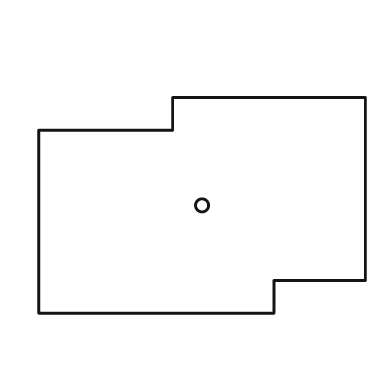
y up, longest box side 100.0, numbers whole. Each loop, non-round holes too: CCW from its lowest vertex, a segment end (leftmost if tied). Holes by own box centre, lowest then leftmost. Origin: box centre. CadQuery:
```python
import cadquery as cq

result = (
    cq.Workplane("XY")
    .moveTo(-50.0, -33.0)
    .lineTo(22.0, -33.0)
    .lineTo(22.0, -23.0)
    .lineTo(50.0, -23.0)
    .lineTo(50.0, 33.0)
    .lineTo(-9.0, 33.0)
    .lineTo(-9.0, 23.0)
    .lineTo(-50.0, 23.0)
    .close()
    .moveTo(0.0, 0.0)
    .circle(2.0)
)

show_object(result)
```